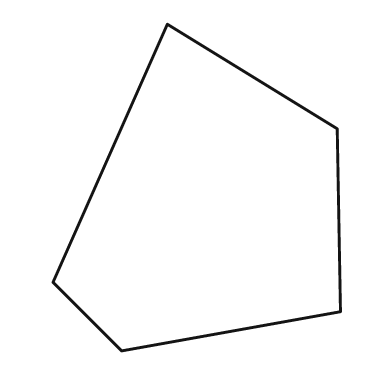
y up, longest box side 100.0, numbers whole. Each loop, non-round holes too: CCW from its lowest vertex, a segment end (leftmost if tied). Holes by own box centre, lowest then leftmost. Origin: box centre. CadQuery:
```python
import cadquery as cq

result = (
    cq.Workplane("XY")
    .moveTo(-23.0, -50.0)
    .lineTo(44.0, -38.0)
    .lineTo(43.0, 18.0)
    .lineTo(-9.0, 50.0)
    .lineTo(-44.0, -29.0)
    .close()
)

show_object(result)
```